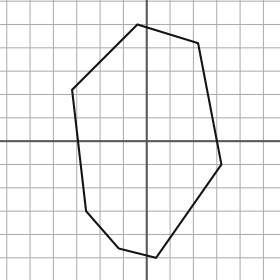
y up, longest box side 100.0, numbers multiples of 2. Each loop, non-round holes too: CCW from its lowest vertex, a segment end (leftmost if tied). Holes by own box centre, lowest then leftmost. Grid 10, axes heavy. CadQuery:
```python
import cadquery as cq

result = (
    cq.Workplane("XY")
    .moveTo(4.0, -50.0)
    .lineTo(32.0, -10.0)
    .lineTo(22.0, 42.0)
    .lineTo(-4.0, 50.0)
    .lineTo(-32.0, 22.0)
    .lineTo(-26.0, -30.0)
    .lineTo(-12.0, -46.0)
    .close()
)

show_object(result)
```